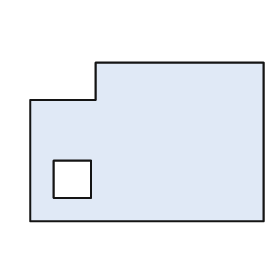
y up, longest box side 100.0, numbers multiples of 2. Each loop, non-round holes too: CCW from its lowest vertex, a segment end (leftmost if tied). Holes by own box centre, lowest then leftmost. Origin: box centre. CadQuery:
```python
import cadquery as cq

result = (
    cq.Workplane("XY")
    .moveTo(-50.0, -34.0)
    .lineTo(50.0, -34.0)
    .lineTo(50.0, 34.0)
    .lineTo(-22.0, 34.0)
    .lineTo(-22.0, 18.0)
    .lineTo(-50.0, 18.0)
    .close()
    .moveTo(-40.0, -24.0)
    .lineTo(-24.0, -24.0)
    .lineTo(-24.0, -8.0)
    .lineTo(-40.0, -8.0)
    .close()
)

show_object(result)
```